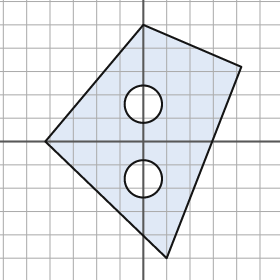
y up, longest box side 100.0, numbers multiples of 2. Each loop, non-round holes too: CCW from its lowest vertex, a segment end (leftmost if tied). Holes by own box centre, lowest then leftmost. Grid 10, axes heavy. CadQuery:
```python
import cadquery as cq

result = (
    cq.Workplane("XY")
    .moveTo(10.0, -50.0)
    .lineTo(42.0, 32.0)
    .lineTo(0.0, 50.0)
    .lineTo(-42.0, 0.0)
    .close()
    .moveTo(0.0, -16.0)
    .circle(8.0)
    .moveTo(0.0, 16.0)
    .circle(8.0)
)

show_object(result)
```